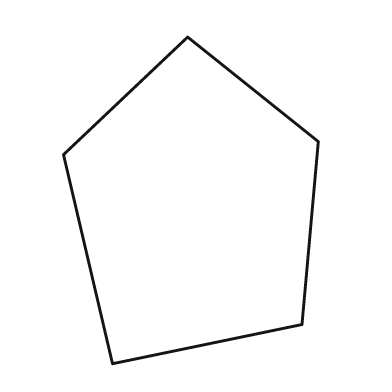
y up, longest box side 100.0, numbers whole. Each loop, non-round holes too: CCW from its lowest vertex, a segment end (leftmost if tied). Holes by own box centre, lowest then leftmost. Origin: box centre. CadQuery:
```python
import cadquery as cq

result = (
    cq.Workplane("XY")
    .moveTo(-24.0, -50.0)
    .lineTo(34.0, -38.0)
    .lineTo(39.0, 18.0)
    .lineTo(-1.0, 50.0)
    .lineTo(-39.0, 14.0)
    .close()
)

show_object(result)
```